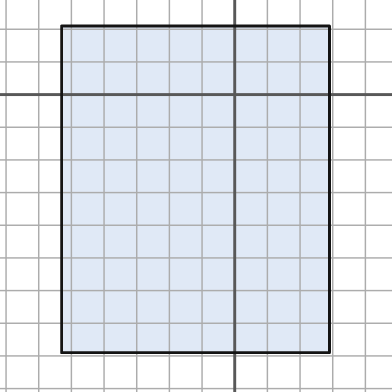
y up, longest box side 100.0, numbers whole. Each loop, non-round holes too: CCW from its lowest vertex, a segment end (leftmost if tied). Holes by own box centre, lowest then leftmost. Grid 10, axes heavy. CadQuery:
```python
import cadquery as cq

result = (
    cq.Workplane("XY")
    .moveTo(-53.0, -79.0)
    .lineTo(29.0, -79.0)
    .lineTo(29.0, 21.0)
    .lineTo(-53.0, 21.0)
    .close()
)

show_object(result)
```